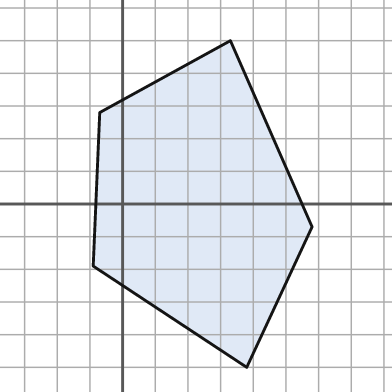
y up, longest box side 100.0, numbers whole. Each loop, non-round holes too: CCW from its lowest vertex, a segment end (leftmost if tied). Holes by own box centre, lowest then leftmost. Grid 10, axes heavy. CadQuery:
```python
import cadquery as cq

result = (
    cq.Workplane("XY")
    .moveTo(38.0, -50.0)
    .lineTo(58.0, -7.0)
    .lineTo(33.0, 50.0)
    .lineTo(-7.0, 28.0)
    .lineTo(-9.0, -19.0)
    .close()
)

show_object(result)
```